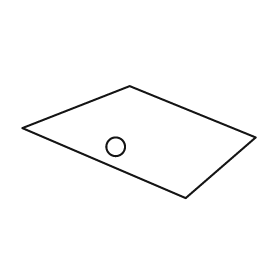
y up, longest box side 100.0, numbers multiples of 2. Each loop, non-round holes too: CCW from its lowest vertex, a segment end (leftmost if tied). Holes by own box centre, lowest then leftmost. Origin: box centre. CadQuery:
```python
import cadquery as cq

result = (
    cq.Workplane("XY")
    .moveTo(20.0, -24.0)
    .lineTo(50.0, 2.0)
    .lineTo(-4.0, 24.0)
    .lineTo(-50.0, 6.0)
    .close()
    .moveTo(-10.0, -2.0)
    .circle(4.0)
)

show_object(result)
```